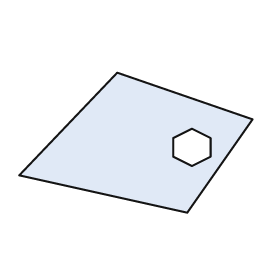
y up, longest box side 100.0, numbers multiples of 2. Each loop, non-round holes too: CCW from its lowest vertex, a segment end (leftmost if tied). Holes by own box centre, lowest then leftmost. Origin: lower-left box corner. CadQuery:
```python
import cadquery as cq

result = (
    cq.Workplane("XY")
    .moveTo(72.0, 0.0)
    .lineTo(100.0, 40.0)
    .lineTo(42.0, 60.0)
    .lineTo(0.0, 16.0)
    .close()
    .moveTo(74.0, 20.0)
    .lineTo(82.0, 24.0)
    .lineTo(82.0, 32.0)
    .lineTo(74.0, 36.0)
    .lineTo(66.0, 32.0)
    .lineTo(66.0, 24.0)
    .close()
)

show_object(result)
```